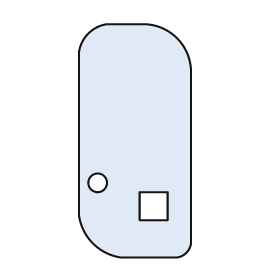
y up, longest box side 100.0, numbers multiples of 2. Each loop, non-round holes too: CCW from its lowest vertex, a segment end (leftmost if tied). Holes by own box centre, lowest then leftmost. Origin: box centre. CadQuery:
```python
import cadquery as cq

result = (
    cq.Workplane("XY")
    .moveTo(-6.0, -50.0)
    .lineTo(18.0, -50.0)
    .threePointArc((22.0, -48.0), (24.0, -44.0))
    .lineTo(24.0, 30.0)
    .threePointArc((18.0, 44.0), (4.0, 50.0))
    .lineTo(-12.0, 50.0)
    .threePointArc((-20.0, 46.0), (-24.0, 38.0))
    .lineTo(-24.0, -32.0)
    .threePointArc((-18.0, -44.0), (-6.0, -50.0))
    .close()
    .moveTo(2.0, -34.0)
    .lineTo(14.0, -34.0)
    .lineTo(14.0, -22.0)
    .lineTo(2.0, -22.0)
    .close()
    .moveTo(-16.0, -18.0)
    .circle(4.0)
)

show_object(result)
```